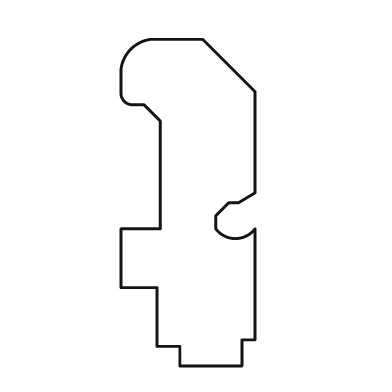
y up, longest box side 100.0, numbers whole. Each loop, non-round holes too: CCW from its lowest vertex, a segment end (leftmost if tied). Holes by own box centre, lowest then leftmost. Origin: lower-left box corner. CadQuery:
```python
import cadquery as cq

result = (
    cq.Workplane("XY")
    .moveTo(18.0, 0.0)
    .lineTo(37.0, 0.0)
    .lineTo(37.0, 8.0)
    .lineTo(41.0, 8.0)
    .lineTo(41.0, 42.0)
    .threePointArc((35.0, 39.0), (29.0, 42.0))
    .lineTo(29.0, 46.0)
    .lineTo(33.0, 50.0)
    .lineTo(36.0, 50.0)
    .lineTo(41.0, 53.0)
    .lineTo(41.0, 84.0)
    .lineTo(25.0, 100.0)
    .lineTo(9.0, 100.0)
    .threePointArc((3.0, 97.0), (0.0, 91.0))
    .lineTo(0.0, 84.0)
    .threePointArc((1.0, 81.0), (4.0, 80.0))
    .lineTo(7.0, 80.0)
    .lineTo(12.0, 75.0)
    .lineTo(12.0, 42.0)
    .lineTo(0.0, 42.0)
    .lineTo(0.0, 24.0)
    .lineTo(11.0, 24.0)
    .lineTo(11.0, 6.0)
    .lineTo(18.0, 6.0)
    .close()
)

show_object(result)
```